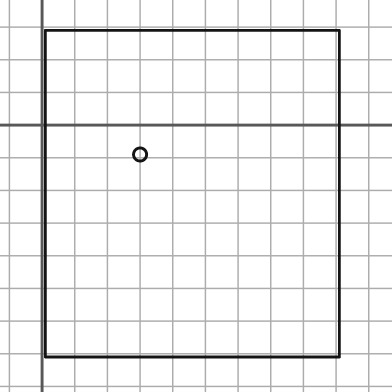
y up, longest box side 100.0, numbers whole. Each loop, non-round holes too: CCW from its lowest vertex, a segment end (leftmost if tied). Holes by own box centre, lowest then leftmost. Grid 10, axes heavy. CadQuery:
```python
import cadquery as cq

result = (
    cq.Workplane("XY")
    .moveTo(1.0, -71.0)
    .lineTo(91.0, -71.0)
    .lineTo(91.0, 29.0)
    .lineTo(1.0, 29.0)
    .close()
    .moveTo(30.0, -9.0)
    .circle(2.0)
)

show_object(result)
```